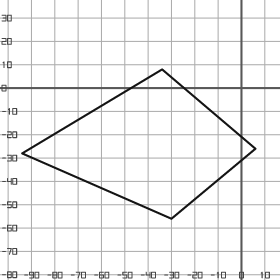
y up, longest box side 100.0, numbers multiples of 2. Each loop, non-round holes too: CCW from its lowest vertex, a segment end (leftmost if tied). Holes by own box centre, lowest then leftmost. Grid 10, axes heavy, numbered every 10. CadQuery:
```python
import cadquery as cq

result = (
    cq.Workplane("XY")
    .moveTo(-30.0, -56.0)
    .lineTo(6.0, -26.0)
    .lineTo(-34.0, 8.0)
    .lineTo(-94.0, -28.0)
    .close()
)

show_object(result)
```